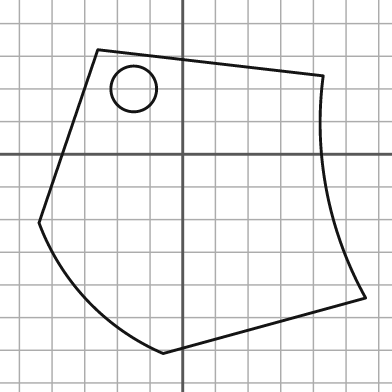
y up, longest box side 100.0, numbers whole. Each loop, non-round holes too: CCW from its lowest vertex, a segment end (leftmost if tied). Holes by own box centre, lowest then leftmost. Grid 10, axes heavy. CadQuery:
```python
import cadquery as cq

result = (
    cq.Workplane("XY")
    .moveTo(-6.0, -61.0)
    .lineTo(56.0, -44.0)
    .threePointArc((44.0, -11.0), (43.0, 24.0))
    .lineTo(-26.0, 32.0)
    .lineTo(-44.0, -21.0)
    .threePointArc((-29.0, -45.0), (-6.0, -61.0))
    .close()
    .moveTo(-15.0, 20.0)
    .circle(7.0)
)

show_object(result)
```